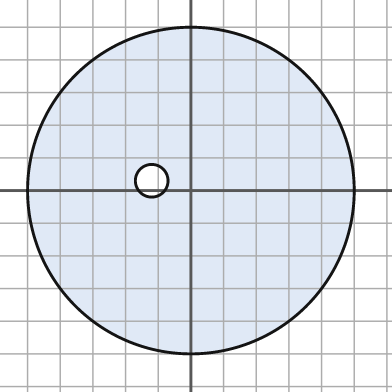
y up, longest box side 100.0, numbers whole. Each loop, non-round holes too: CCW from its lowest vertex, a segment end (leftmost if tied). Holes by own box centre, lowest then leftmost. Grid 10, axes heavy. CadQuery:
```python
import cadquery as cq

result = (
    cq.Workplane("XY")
    .moveTo(0.0, 0.0)
    .circle(50.0)
    .moveTo(-12.0, 3.0)
    .circle(5.0)
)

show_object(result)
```